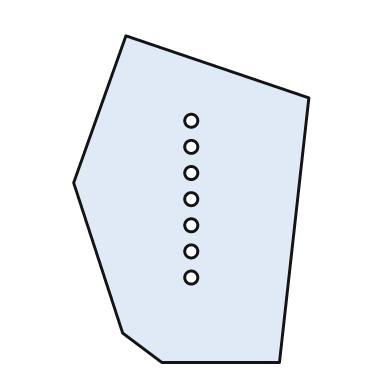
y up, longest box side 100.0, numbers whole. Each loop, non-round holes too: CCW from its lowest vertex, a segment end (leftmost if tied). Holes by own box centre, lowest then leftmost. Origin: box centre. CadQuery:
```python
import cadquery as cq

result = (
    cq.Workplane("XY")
    .moveTo(-9.0, -50.0)
    .lineTo(27.0, -50.0)
    .lineTo(36.0, 31.0)
    .lineTo(-20.0, 50.0)
    .lineTo(-36.0, 5.0)
    .lineTo(-21.0, -41.0)
    .close()
    .moveTo(0.0, -24.0)
    .circle(2.0)
    .moveTo(0.0, -16.0)
    .circle(2.0)
    .moveTo(0.0, -8.0)
    .circle(2.0)
    .moveTo(0.0, 0.0)
    .circle(2.0)
    .moveTo(0.0, 8.0)
    .circle(2.0)
    .moveTo(0.0, 16.0)
    .circle(2.0)
    .moveTo(0.0, 24.0)
    .circle(2.0)
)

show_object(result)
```